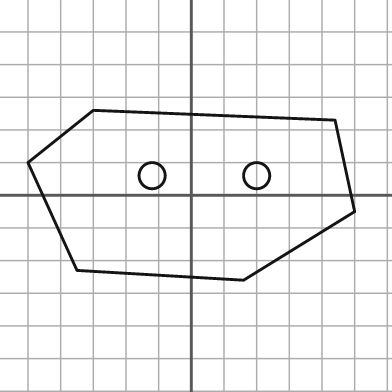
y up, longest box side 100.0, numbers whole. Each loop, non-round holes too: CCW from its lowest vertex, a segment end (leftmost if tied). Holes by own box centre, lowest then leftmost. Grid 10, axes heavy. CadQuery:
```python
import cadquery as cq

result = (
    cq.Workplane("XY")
    .moveTo(16.0, -26.0)
    .lineTo(50.0, -5.0)
    .lineTo(44.0, 23.0)
    .lineTo(-30.0, 26.0)
    .lineTo(-50.0, 10.0)
    .lineTo(-35.0, -23.0)
    .close()
    .moveTo(-12.0, 6.0)
    .circle(4.0)
    .moveTo(20.0, 6.0)
    .circle(4.0)
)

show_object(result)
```